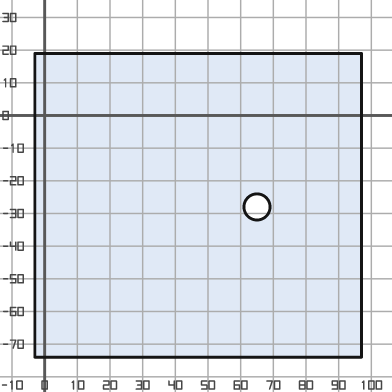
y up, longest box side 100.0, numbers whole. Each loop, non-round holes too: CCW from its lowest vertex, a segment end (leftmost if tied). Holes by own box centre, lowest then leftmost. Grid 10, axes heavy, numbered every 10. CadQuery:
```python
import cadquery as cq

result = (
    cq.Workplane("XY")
    .moveTo(-3.0, -74.0)
    .lineTo(97.0, -74.0)
    .lineTo(97.0, 19.0)
    .lineTo(-3.0, 19.0)
    .close()
    .moveTo(65.0, -28.0)
    .circle(4.0)
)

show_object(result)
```